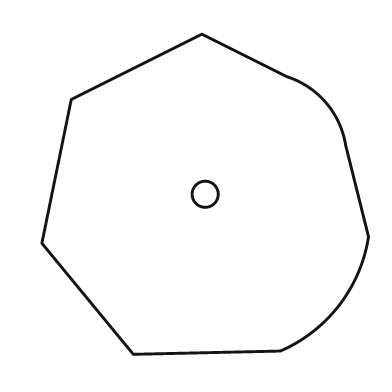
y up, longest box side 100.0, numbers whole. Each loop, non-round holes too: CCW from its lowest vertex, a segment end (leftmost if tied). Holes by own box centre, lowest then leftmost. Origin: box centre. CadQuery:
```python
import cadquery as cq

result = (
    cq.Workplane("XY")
    .moveTo(-22.0, -49.0)
    .lineTo(23.0, -48.0)
    .threePointArc((41.0, -34.0), (50.0, -13.0))
    .lineTo(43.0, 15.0)
    .threePointArc((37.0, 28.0), (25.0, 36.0))
    .lineTo(-1.0, 49.0)
    .lineTo(-41.0, 29.0)
    .lineTo(-50.0, -15.0)
    .close()
    .moveTo(0.0, 0.0)
    .circle(4.0)
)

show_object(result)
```